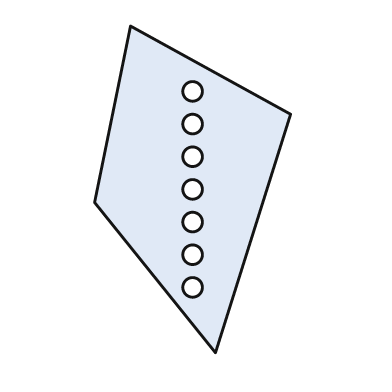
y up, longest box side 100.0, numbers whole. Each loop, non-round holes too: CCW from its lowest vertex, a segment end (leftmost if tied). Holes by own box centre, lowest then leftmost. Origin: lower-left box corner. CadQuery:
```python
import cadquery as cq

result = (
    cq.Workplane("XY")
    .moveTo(37.0, 0.0)
    .lineTo(60.0, 73.0)
    .lineTo(11.0, 100.0)
    .lineTo(0.0, 46.0)
    .close()
    .moveTo(30.0, 20.0)
    .circle(3.0)
    .moveTo(30.0, 30.0)
    .circle(3.0)
    .moveTo(30.0, 40.0)
    .circle(3.0)
    .moveTo(30.0, 50.0)
    .circle(3.0)
    .moveTo(30.0, 60.0)
    .circle(3.0)
    .moveTo(30.0, 70.0)
    .circle(3.0)
    .moveTo(30.0, 80.0)
    .circle(3.0)
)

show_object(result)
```